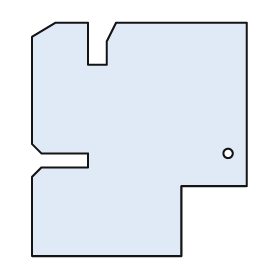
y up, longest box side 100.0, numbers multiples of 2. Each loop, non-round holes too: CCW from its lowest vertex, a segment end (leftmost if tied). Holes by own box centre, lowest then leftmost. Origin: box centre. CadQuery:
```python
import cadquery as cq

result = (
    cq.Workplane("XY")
    .moveTo(-46.0, -50.0)
    .lineTo(18.0, -50.0)
    .lineTo(18.0, -20.0)
    .lineTo(46.0, -20.0)
    .lineTo(46.0, 50.0)
    .lineTo(-10.0, 50.0)
    .lineTo(-14.0, 42.0)
    .lineTo(-14.0, 32.0)
    .lineTo(-22.0, 32.0)
    .lineTo(-22.0, 50.0)
    .lineTo(-36.0, 50.0)
    .lineTo(-46.0, 44.0)
    .lineTo(-46.0, -2.0)
    .lineTo(-42.0, -6.0)
    .lineTo(-22.0, -6.0)
    .lineTo(-22.0, -12.0)
    .lineTo(-42.0, -12.0)
    .lineTo(-46.0, -16.0)
    .close()
    .moveTo(38.0, -6.0)
    .circle(2.0)
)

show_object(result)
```